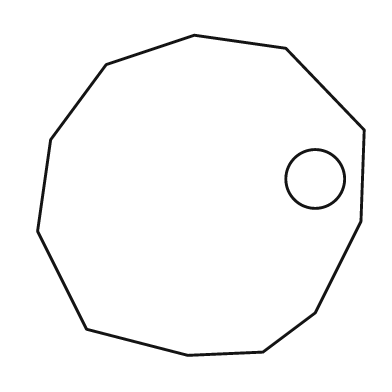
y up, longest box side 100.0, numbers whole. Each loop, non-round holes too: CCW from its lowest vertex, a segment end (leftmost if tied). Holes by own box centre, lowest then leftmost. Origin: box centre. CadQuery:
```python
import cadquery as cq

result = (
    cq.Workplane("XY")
    .moveTo(-4.0, -49.0)
    .lineTo(19.0, -48.0)
    .lineTo(35.0, -36.0)
    .lineTo(49.0, -8.0)
    .lineTo(50.0, 20.0)
    .lineTo(26.0, 45.0)
    .lineTo(-2.0, 49.0)
    .lineTo(-29.0, 40.0)
    .lineTo(-46.0, 17.0)
    .lineTo(-50.0, -11.0)
    .lineTo(-35.0, -41.0)
    .close()
    .moveTo(35.0, 5.0)
    .circle(9.0)
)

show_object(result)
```